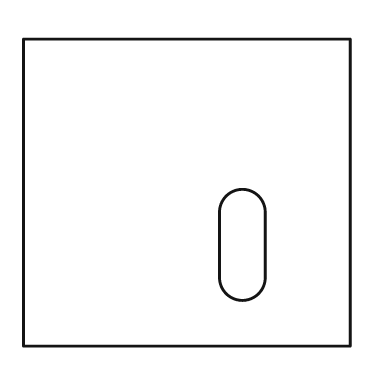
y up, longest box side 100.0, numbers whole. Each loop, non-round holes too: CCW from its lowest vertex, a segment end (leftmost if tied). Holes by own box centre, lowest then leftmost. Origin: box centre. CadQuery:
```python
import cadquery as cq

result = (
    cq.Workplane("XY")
    .moveTo(-50.0, -47.0)
    .lineTo(50.0, -47.0)
    .lineTo(50.0, 47.0)
    .lineTo(-50.0, 47.0)
    .close()
    .moveTo(10.0, -26.0)
    .threePointArc((17.0, -33.0), (24.0, -26.0))
    .lineTo(24.0, -6.0)
    .threePointArc((17.0, 1.0), (10.0, -6.0))
    .close()
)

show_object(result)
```